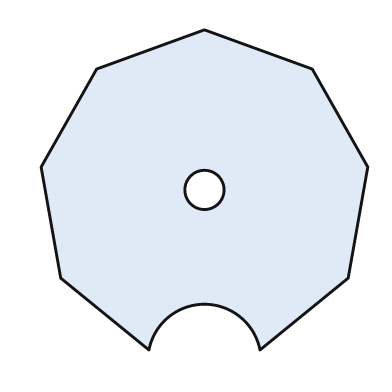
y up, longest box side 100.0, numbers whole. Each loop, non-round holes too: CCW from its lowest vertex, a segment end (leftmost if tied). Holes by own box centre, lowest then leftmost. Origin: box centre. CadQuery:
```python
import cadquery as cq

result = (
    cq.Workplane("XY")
    .moveTo(-17.0, -49.0)
    .threePointArc((0.0, -35.0), (17.0, -49.0))
    .lineTo(44.0, -27.0)
    .lineTo(50.0, 7.0)
    .lineTo(33.0, 37.0)
    .lineTo(0.0, 49.0)
    .lineTo(-33.0, 37.0)
    .lineTo(-50.0, 7.0)
    .lineTo(-44.0, -27.0)
    .close()
    .moveTo(0.0, 0.0)
    .circle(6.0)
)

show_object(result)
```